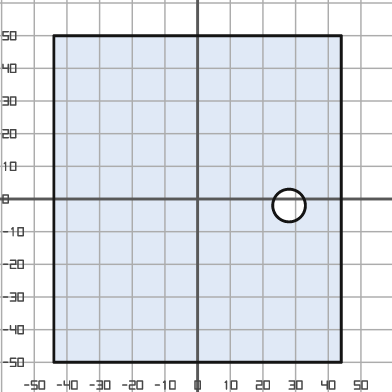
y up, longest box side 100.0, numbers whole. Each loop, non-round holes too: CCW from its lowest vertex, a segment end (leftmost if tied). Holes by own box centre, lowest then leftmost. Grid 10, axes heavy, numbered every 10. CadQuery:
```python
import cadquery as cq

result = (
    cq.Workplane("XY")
    .moveTo(-44.0, -50.0)
    .lineTo(44.0, -50.0)
    .lineTo(44.0, 50.0)
    .lineTo(-44.0, 50.0)
    .close()
    .moveTo(28.0, -2.0)
    .circle(5.0)
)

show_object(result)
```